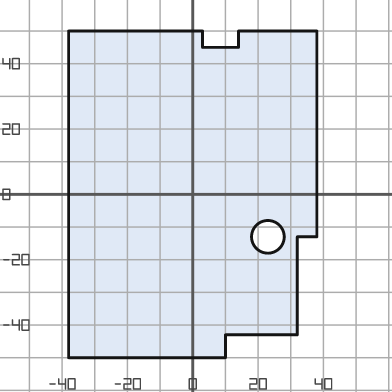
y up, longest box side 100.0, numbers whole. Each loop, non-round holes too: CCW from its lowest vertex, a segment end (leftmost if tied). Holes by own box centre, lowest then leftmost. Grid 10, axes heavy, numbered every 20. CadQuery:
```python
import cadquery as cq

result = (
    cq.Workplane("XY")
    .moveTo(-38.0, -50.0)
    .lineTo(10.0, -50.0)
    .lineTo(10.0, -43.0)
    .lineTo(32.0, -43.0)
    .lineTo(32.0, -13.0)
    .lineTo(38.0, -13.0)
    .lineTo(38.0, 50.0)
    .lineTo(14.0, 50.0)
    .lineTo(14.0, 45.0)
    .lineTo(3.0, 45.0)
    .lineTo(3.0, 50.0)
    .lineTo(-38.0, 50.0)
    .close()
    .moveTo(23.0, -13.0)
    .circle(5.0)
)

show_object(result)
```